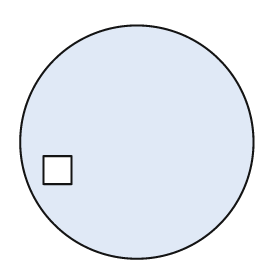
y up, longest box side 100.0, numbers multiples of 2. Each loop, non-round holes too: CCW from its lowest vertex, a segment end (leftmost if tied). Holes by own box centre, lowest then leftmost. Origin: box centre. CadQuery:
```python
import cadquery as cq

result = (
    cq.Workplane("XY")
    .moveTo(0.0, 0.0)
    .circle(50.0)
    .moveTo(-40.0, -18.0)
    .lineTo(-28.0, -18.0)
    .lineTo(-28.0, -6.0)
    .lineTo(-40.0, -6.0)
    .close()
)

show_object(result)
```